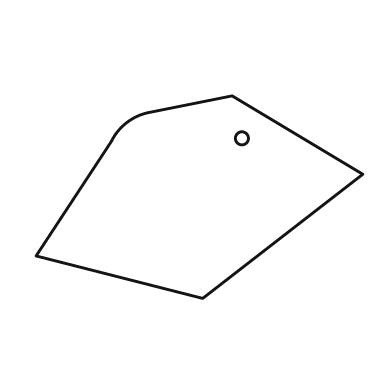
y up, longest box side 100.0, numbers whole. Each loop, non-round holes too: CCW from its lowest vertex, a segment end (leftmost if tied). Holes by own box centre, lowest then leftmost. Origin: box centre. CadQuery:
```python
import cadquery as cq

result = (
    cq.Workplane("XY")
    .moveTo(1.0, -31.0)
    .lineTo(50.0, 7.0)
    .lineTo(10.0, 31.0)
    .lineTo(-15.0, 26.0)
    .threePointArc((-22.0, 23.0), (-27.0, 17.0))
    .lineTo(-50.0, -18.0)
    .close()
    .moveTo(13.0, 18.0)
    .circle(2.0)
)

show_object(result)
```